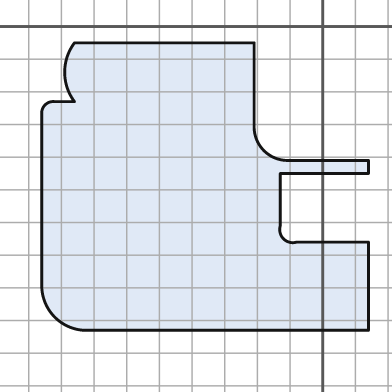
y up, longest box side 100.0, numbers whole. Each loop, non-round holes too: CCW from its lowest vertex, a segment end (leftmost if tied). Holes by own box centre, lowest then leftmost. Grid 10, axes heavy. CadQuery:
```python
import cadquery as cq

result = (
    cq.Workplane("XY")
    .moveTo(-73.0, -93.0)
    .lineTo(14.0, -93.0)
    .lineTo(14.0, -66.0)
    .lineTo(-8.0, -66.0)
    .threePointArc((-12.0, -65.0), (-13.0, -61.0))
    .lineTo(-13.0, -45.0)
    .lineTo(14.0, -45.0)
    .lineTo(14.0, -41.0)
    .lineTo(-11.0, -41.0)
    .threePointArc((-18.0, -38.0), (-21.0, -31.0))
    .lineTo(-21.0, -5.0)
    .lineTo(-76.0, -5.0)
    .threePointArc((-79.0, -14.0), (-76.0, -23.0))
    .lineTo(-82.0, -23.0)
    .threePointArc((-85.0, -24.0), (-86.0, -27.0))
    .lineTo(-86.0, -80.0)
    .threePointArc((-82.0, -89.0), (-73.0, -93.0))
    .close()
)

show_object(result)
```